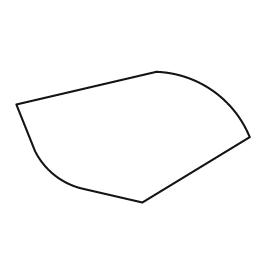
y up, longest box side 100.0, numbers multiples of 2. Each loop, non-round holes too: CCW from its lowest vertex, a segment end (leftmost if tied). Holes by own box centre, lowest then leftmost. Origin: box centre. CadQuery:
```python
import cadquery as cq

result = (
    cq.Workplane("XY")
    .moveTo(4.0, -28.0)
    .lineTo(50.0, 0.0)
    .threePointArc((34.0, 20.0), (10.0, 28.0))
    .lineTo(-50.0, 14.0)
    .lineTo(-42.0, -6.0)
    .threePointArc((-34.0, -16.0), (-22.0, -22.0))
    .close()
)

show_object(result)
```